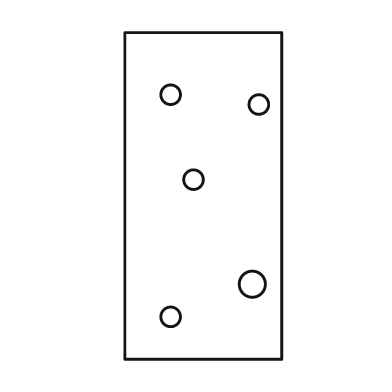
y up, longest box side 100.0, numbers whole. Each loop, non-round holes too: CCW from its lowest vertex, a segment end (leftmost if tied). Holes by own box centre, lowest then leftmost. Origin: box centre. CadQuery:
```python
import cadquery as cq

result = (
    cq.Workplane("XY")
    .moveTo(-24.0, -50.0)
    .lineTo(24.0, -50.0)
    .lineTo(24.0, 50.0)
    .lineTo(-24.0, 50.0)
    .close()
    .moveTo(-10.0, -37.0)
    .circle(3.0)
    .moveTo(15.0, -27.0)
    .circle(4.0)
    .moveTo(-3.0, 5.0)
    .circle(3.0)
    .moveTo(17.0, 28.0)
    .circle(3.0)
    .moveTo(-10.0, 31.0)
    .circle(3.0)
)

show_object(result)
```